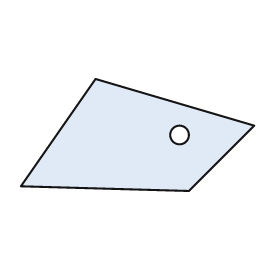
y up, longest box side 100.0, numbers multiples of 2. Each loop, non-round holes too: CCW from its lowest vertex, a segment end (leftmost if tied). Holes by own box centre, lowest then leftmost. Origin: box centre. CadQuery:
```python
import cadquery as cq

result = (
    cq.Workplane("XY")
    .moveTo(22.0, -24.0)
    .lineTo(50.0, 4.0)
    .lineTo(-18.0, 24.0)
    .lineTo(-50.0, -22.0)
    .close()
    .moveTo(18.0, 0.0)
    .circle(4.0)
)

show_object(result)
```